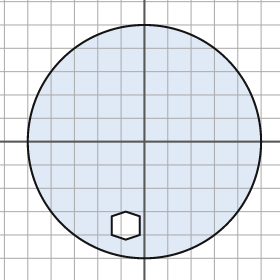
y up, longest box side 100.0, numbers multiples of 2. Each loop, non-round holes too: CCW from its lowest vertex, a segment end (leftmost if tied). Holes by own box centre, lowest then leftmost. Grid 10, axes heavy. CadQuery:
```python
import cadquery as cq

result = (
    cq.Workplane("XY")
    .moveTo(0.0, 0.0)
    .circle(50.0)
    .moveTo(-8.0, -42.0)
    .lineTo(-2.0, -40.0)
    .lineTo(-2.0, -32.0)
    .lineTo(-8.0, -30.0)
    .lineTo(-14.0, -32.0)
    .lineTo(-14.0, -40.0)
    .close()
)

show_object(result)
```